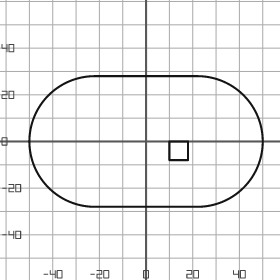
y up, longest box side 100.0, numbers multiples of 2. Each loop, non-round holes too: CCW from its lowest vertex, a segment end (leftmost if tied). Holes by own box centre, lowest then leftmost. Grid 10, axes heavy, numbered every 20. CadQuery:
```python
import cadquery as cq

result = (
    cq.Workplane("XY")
    .moveTo(-22.0, -28.0)
    .lineTo(22.0, -28.0)
    .threePointArc((50.0, 0.0), (22.0, 28.0))
    .lineTo(-22.0, 28.0)
    .threePointArc((-50.0, 0.0), (-22.0, -28.0))
    .close()
    .moveTo(10.0, -8.0)
    .lineTo(18.0, -8.0)
    .lineTo(18.0, 0.0)
    .lineTo(10.0, 0.0)
    .close()
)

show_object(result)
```